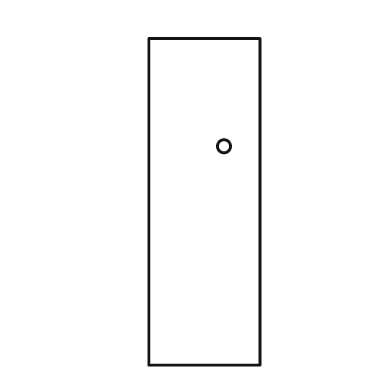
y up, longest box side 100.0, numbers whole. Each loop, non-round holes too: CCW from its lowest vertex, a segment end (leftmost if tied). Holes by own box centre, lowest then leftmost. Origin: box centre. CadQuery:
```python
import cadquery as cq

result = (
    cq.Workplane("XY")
    .moveTo(-17.0, -50.0)
    .lineTo(17.0, -50.0)
    .lineTo(17.0, 50.0)
    .lineTo(-17.0, 50.0)
    .close()
    .moveTo(6.0, 17.0)
    .circle(2.0)
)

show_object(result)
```